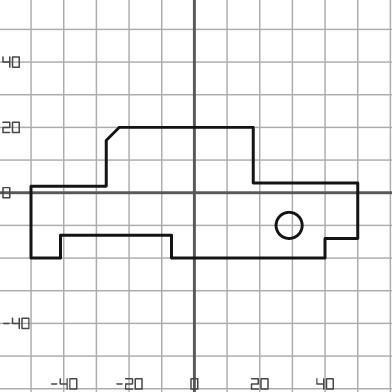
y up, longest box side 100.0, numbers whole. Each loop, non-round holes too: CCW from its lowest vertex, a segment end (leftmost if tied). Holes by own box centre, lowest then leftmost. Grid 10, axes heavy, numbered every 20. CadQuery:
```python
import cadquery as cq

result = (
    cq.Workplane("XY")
    .moveTo(-50.0, -20.0)
    .lineTo(-41.0, -20.0)
    .lineTo(-41.0, -13.0)
    .lineTo(-7.0, -13.0)
    .lineTo(-7.0, -20.0)
    .lineTo(40.0, -20.0)
    .lineTo(40.0, -14.0)
    .lineTo(50.0, -14.0)
    .lineTo(50.0, 3.0)
    .lineTo(18.0, 3.0)
    .lineTo(18.0, 20.0)
    .lineTo(-23.0, 20.0)
    .lineTo(-27.0, 16.0)
    .lineTo(-27.0, 2.0)
    .lineTo(-50.0, 2.0)
    .close()
    .moveTo(29.0, -10.0)
    .circle(4.0)
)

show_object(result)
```